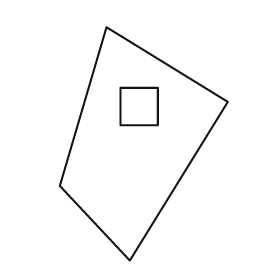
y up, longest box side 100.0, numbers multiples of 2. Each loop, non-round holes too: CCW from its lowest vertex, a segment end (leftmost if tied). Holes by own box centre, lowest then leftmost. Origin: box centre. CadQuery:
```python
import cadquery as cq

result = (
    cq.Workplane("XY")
    .moveTo(-6.0, -50.0)
    .lineTo(36.0, 18.0)
    .lineTo(-16.0, 50.0)
    .lineTo(-36.0, -18.0)
    .close()
    .moveTo(-10.0, 8.0)
    .lineTo(6.0, 8.0)
    .lineTo(6.0, 24.0)
    .lineTo(-10.0, 24.0)
    .close()
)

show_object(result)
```